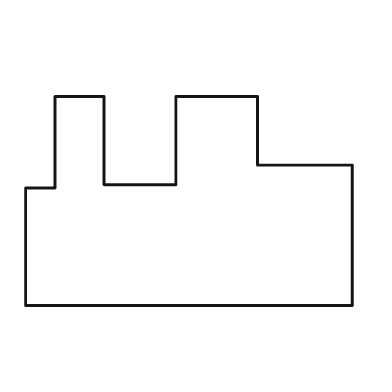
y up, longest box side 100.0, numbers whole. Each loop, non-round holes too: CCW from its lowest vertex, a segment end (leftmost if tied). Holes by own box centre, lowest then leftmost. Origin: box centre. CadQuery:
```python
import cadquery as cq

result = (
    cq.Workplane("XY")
    .moveTo(-50.0, -32.0)
    .lineTo(50.0, -32.0)
    .lineTo(50.0, 11.0)
    .lineTo(21.0, 11.0)
    .lineTo(21.0, 32.0)
    .lineTo(-4.0, 32.0)
    .lineTo(-4.0, 5.0)
    .lineTo(-26.0, 5.0)
    .lineTo(-26.0, 32.0)
    .lineTo(-41.0, 32.0)
    .lineTo(-41.0, 4.0)
    .lineTo(-50.0, 4.0)
    .close()
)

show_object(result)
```